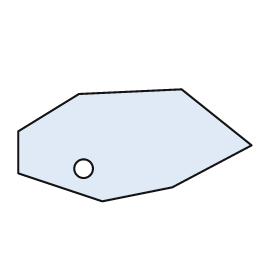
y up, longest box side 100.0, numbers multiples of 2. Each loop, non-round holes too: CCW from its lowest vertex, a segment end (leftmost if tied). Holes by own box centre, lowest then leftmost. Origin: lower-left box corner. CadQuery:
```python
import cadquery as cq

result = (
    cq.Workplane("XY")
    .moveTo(36.0, 0.0)
    .lineTo(66.0, 6.0)
    .lineTo(100.0, 24.0)
    .lineTo(70.0, 48.0)
    .lineTo(26.0, 46.0)
    .lineTo(0.0, 30.0)
    .lineTo(0.0, 12.0)
    .close()
    .moveTo(28.0, 14.0)
    .circle(4.0)
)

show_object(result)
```